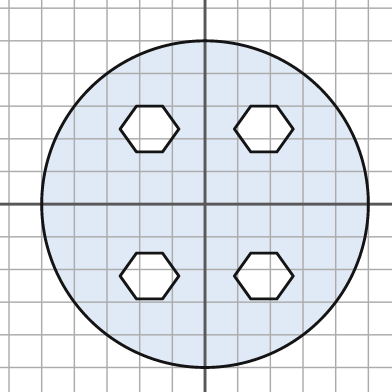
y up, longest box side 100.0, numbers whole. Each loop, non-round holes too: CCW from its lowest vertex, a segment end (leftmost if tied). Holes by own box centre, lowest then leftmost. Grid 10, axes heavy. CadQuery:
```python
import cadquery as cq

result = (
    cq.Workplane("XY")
    .moveTo(0.0, 0.0)
    .circle(50.0)
    .moveTo(-21.0, -29.0)
    .lineTo(-13.0, -29.0)
    .lineTo(-8.0, -22.0)
    .lineTo(-13.0, -15.0)
    .lineTo(-21.0, -15.0)
    .lineTo(-26.0, -22.0)
    .close()
    .moveTo(14.0, -29.0)
    .lineTo(22.0, -29.0)
    .lineTo(27.0, -22.0)
    .lineTo(22.0, -15.0)
    .lineTo(14.0, -15.0)
    .lineTo(9.0, -22.0)
    .close()
    .moveTo(-21.0, 16.0)
    .lineTo(-13.0, 16.0)
    .lineTo(-8.0, 23.0)
    .lineTo(-13.0, 30.0)
    .lineTo(-21.0, 30.0)
    .lineTo(-26.0, 23.0)
    .close()
    .moveTo(14.0, 16.0)
    .lineTo(22.0, 16.0)
    .lineTo(27.0, 23.0)
    .lineTo(22.0, 30.0)
    .lineTo(14.0, 30.0)
    .lineTo(9.0, 23.0)
    .close()
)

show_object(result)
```